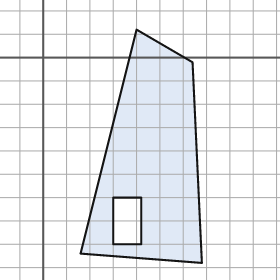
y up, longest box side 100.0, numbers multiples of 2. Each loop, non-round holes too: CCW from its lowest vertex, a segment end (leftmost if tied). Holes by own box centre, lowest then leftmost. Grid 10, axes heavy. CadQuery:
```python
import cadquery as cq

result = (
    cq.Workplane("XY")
    .moveTo(68.0, -88.0)
    .lineTo(64.0, -2.0)
    .lineTo(40.0, 12.0)
    .lineTo(16.0, -84.0)
    .close()
    .moveTo(30.0, -80.0)
    .lineTo(42.0, -80.0)
    .lineTo(42.0, -60.0)
    .lineTo(30.0, -60.0)
    .close()
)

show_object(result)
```